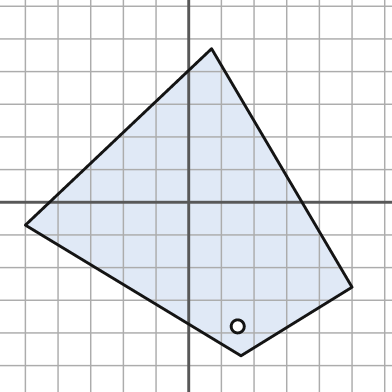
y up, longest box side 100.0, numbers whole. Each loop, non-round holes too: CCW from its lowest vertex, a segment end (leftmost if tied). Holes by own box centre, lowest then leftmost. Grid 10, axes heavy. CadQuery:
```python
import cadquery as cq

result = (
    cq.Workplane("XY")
    .moveTo(16.0, -47.0)
    .lineTo(50.0, -26.0)
    .lineTo(7.0, 47.0)
    .lineTo(-50.0, -7.0)
    .close()
    .moveTo(15.0, -38.0)
    .circle(2.0)
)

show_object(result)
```